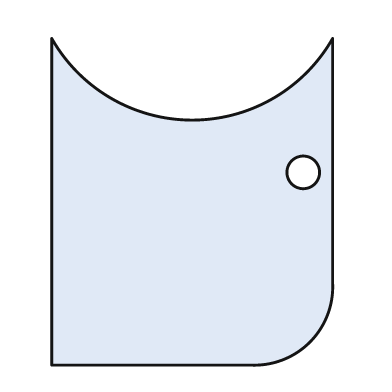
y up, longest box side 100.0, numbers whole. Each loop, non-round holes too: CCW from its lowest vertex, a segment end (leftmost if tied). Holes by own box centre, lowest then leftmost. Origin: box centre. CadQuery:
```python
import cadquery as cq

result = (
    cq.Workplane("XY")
    .moveTo(-43.0, -50.0)
    .lineTo(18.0, -50.0)
    .threePointArc((36.0, -43.0), (43.0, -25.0))
    .lineTo(43.0, 50.0)
    .threePointArc((0.0, 25.0), (-43.0, 50.0))
    .close()
    .moveTo(34.0, 9.0)
    .circle(5.0)
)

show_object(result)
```